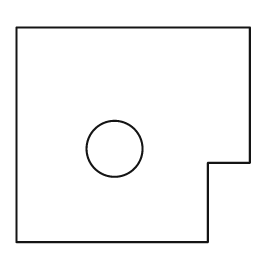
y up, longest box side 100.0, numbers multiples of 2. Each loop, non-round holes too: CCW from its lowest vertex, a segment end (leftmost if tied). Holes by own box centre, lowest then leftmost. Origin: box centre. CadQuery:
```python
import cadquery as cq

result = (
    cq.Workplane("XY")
    .moveTo(-50.0, -46.0)
    .lineTo(32.0, -46.0)
    .lineTo(32.0, -12.0)
    .lineTo(50.0, -12.0)
    .lineTo(50.0, 46.0)
    .lineTo(-50.0, 46.0)
    .close()
    .moveTo(-8.0, -6.0)
    .circle(12.0)
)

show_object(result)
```